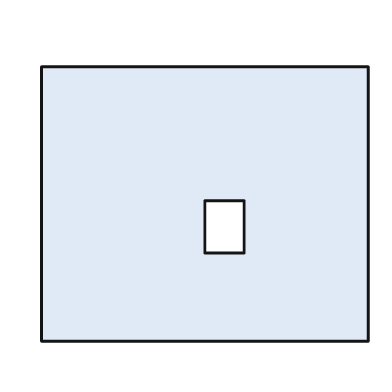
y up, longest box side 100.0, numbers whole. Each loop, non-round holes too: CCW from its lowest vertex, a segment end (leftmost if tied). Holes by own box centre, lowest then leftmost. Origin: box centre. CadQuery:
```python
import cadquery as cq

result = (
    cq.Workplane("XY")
    .moveTo(-50.0, -42.0)
    .lineTo(50.0, -42.0)
    .lineTo(50.0, 42.0)
    .lineTo(-50.0, 42.0)
    .close()
    .moveTo(0.0, -15.0)
    .lineTo(12.0, -15.0)
    .lineTo(12.0, 1.0)
    .lineTo(0.0, 1.0)
    .close()
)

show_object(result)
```